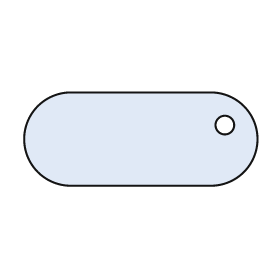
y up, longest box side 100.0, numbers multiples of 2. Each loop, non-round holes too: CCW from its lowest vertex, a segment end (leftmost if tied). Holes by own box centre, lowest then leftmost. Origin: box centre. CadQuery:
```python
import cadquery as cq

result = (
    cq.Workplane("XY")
    .moveTo(-30.0, -20.0)
    .lineTo(30.0, -20.0)
    .threePointArc((50.0, 0.0), (30.0, 20.0))
    .lineTo(-30.0, 20.0)
    .threePointArc((-50.0, 0.0), (-30.0, -20.0))
    .close()
    .moveTo(36.0, 6.0)
    .circle(4.0)
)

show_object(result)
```